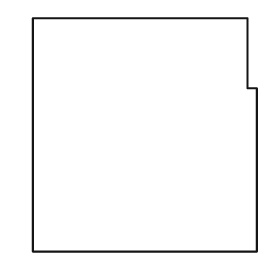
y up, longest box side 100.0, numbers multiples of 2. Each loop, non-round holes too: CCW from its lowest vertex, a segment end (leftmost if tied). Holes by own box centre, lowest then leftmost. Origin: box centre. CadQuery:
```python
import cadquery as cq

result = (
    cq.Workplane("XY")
    .moveTo(-48.0, -50.0)
    .lineTo(48.0, -50.0)
    .lineTo(48.0, 20.0)
    .lineTo(44.0, 20.0)
    .lineTo(44.0, 50.0)
    .lineTo(-48.0, 50.0)
    .close()
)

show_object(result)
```